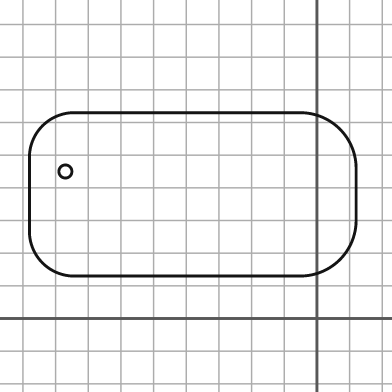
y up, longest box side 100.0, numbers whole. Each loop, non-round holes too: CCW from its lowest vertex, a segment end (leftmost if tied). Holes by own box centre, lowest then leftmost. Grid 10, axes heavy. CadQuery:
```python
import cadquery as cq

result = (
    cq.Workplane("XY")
    .moveTo(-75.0, 13.0)
    .lineTo(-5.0, 13.0)
    .threePointArc((7.0, 18.0), (12.0, 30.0))
    .lineTo(12.0, 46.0)
    .threePointArc((7.0, 58.0), (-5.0, 63.0))
    .lineTo(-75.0, 63.0)
    .threePointArc((-84.0, 59.0), (-88.0, 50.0))
    .lineTo(-88.0, 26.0)
    .threePointArc((-84.0, 17.0), (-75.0, 13.0))
    .close()
    .moveTo(-77.0, 45.0)
    .circle(2.0)
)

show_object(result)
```